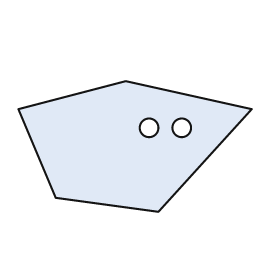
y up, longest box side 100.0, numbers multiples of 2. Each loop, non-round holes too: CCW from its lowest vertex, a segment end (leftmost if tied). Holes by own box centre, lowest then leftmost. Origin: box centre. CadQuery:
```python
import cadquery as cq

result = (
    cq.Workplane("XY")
    .moveTo(10.0, -28.0)
    .lineTo(50.0, 16.0)
    .lineTo(-4.0, 28.0)
    .lineTo(-50.0, 16.0)
    .lineTo(-34.0, -22.0)
    .close()
    .moveTo(6.0, 8.0)
    .circle(4.0)
    .moveTo(20.0, 8.0)
    .circle(4.0)
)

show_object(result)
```